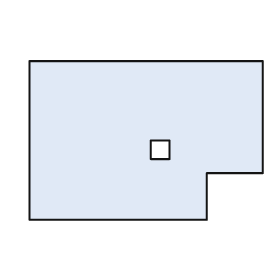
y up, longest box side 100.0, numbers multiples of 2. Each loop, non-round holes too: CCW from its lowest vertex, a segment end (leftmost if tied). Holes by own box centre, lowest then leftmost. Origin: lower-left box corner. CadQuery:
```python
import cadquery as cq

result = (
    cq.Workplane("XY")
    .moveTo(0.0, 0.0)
    .lineTo(76.0, 0.0)
    .lineTo(76.0, 20.0)
    .lineTo(100.0, 20.0)
    .lineTo(100.0, 68.0)
    .lineTo(0.0, 68.0)
    .close()
    .moveTo(52.0, 26.0)
    .lineTo(60.0, 26.0)
    .lineTo(60.0, 34.0)
    .lineTo(52.0, 34.0)
    .close()
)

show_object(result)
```